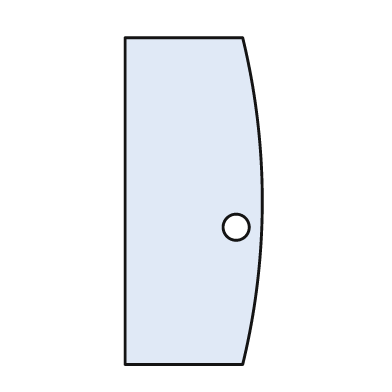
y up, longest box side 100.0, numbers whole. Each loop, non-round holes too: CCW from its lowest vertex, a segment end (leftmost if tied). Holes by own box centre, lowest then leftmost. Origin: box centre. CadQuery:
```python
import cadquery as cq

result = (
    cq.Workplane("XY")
    .moveTo(-21.0, -50.0)
    .lineTo(15.0, -50.0)
    .threePointArc((21.0, 0.0), (15.0, 50.0))
    .lineTo(-21.0, 50.0)
    .close()
    .moveTo(13.0, -8.0)
    .circle(4.0)
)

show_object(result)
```